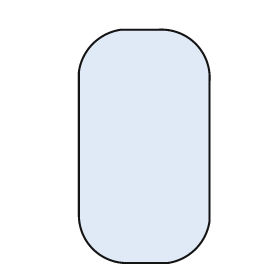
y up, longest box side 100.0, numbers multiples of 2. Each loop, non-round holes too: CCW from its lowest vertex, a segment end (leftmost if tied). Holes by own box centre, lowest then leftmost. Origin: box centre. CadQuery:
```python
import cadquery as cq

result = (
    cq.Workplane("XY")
    .moveTo(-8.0, -50.0)
    .lineTo(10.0, -50.0)
    .threePointArc((22.0, -44.0), (28.0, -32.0))
    .lineTo(28.0, 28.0)
    .threePointArc((22.0, 44.0), (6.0, 50.0))
    .lineTo(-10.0, 50.0)
    .threePointArc((-22.0, 44.0), (-28.0, 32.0))
    .lineTo(-28.0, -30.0)
    .threePointArc((-22.0, -44.0), (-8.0, -50.0))
    .close()
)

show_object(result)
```